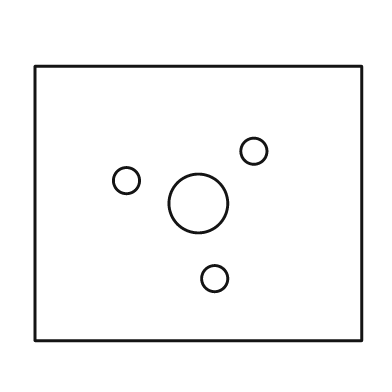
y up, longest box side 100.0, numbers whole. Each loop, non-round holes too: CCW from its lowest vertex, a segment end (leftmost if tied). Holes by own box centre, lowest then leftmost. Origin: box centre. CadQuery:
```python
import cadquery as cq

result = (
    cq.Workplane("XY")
    .moveTo(-50.0, -42.0)
    .lineTo(50.0, -42.0)
    .lineTo(50.0, 42.0)
    .lineTo(-50.0, 42.0)
    .close()
    .moveTo(5.0, -23.0)
    .circle(4.0)
    .moveTo(0.0, 0.0)
    .circle(9.0)
    .moveTo(-22.0, 7.0)
    .circle(4.0)
    .moveTo(17.0, 16.0)
    .circle(4.0)
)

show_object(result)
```